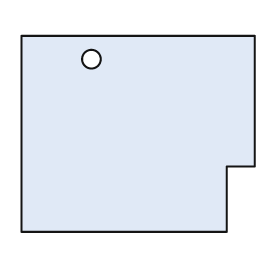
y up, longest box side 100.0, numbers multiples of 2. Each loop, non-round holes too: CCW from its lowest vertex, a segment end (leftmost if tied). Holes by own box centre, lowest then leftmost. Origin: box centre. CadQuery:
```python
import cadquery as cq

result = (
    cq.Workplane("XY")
    .moveTo(-50.0, -42.0)
    .lineTo(38.0, -42.0)
    .lineTo(38.0, -14.0)
    .lineTo(50.0, -14.0)
    .lineTo(50.0, 42.0)
    .lineTo(-50.0, 42.0)
    .close()
    .moveTo(-20.0, 32.0)
    .circle(4.0)
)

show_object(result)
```